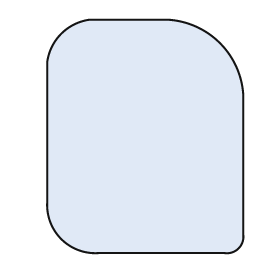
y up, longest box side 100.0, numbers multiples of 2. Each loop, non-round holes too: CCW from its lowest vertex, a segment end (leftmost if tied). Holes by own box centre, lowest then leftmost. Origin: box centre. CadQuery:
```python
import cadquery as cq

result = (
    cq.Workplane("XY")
    .moveTo(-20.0, -50.0)
    .lineTo(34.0, -50.0)
    .threePointArc((40.0, -48.0), (42.0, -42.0))
    .lineTo(42.0, 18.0)
    .threePointArc((32.0, 40.0), (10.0, 50.0))
    .lineTo(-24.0, 50.0)
    .threePointArc((-36.0, 44.0), (-42.0, 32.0))
    .lineTo(-42.0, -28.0)
    .threePointArc((-36.0, -44.0), (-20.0, -50.0))
    .close()
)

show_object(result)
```